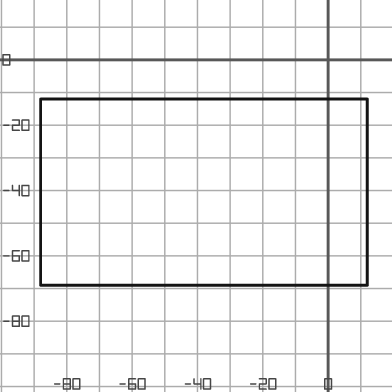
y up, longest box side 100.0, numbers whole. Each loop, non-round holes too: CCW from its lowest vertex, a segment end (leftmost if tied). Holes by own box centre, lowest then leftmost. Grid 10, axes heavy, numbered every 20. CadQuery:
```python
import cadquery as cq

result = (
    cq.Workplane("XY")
    .moveTo(-88.0, -69.0)
    .lineTo(12.0, -69.0)
    .lineTo(12.0, -12.0)
    .lineTo(-88.0, -12.0)
    .close()
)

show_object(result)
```